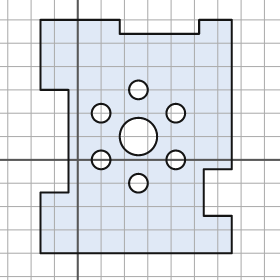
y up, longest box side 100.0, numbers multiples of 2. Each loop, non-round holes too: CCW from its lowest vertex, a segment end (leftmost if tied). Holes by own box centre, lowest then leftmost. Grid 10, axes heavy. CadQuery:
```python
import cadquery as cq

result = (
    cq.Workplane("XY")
    .moveTo(-16.0, -40.0)
    .lineTo(66.0, -40.0)
    .lineTo(66.0, -24.0)
    .lineTo(54.0, -24.0)
    .lineTo(54.0, -4.0)
    .lineTo(66.0, -4.0)
    .lineTo(66.0, 60.0)
    .lineTo(52.0, 60.0)
    .lineTo(52.0, 54.0)
    .lineTo(18.0, 54.0)
    .lineTo(18.0, 60.0)
    .lineTo(-16.0, 60.0)
    .lineTo(-16.0, 30.0)
    .lineTo(-4.0, 30.0)
    .lineTo(-4.0, -14.0)
    .lineTo(-16.0, -14.0)
    .close()
    .moveTo(26.0, -10.0)
    .circle(4.0)
    .moveTo(10.0, 0.0)
    .circle(4.0)
    .moveTo(42.0, 0.0)
    .circle(4.0)
    .moveTo(26.0, 10.0)
    .circle(8.0)
    .moveTo(10.0, 20.0)
    .circle(4.0)
    .moveTo(42.0, 20.0)
    .circle(4.0)
    .moveTo(26.0, 30.0)
    .circle(4.0)
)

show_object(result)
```